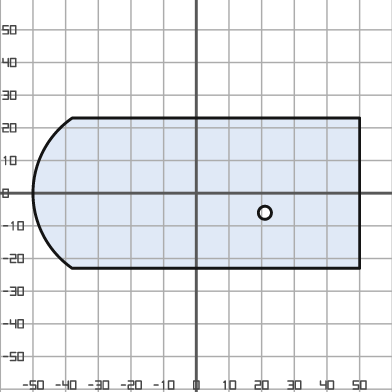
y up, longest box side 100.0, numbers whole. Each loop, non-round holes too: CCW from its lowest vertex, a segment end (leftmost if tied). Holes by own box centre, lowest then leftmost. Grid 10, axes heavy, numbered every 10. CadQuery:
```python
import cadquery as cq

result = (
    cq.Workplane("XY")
    .moveTo(-38.0, -23.0)
    .lineTo(50.0, -23.0)
    .lineTo(50.0, 23.0)
    .lineTo(-38.0, 23.0)
    .threePointArc((-50.0, 0.0), (-38.0, -23.0))
    .close()
    .moveTo(21.0, -6.0)
    .circle(2.0)
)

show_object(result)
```